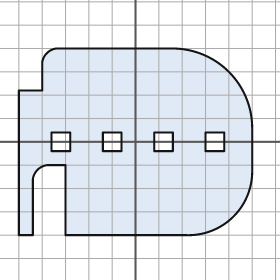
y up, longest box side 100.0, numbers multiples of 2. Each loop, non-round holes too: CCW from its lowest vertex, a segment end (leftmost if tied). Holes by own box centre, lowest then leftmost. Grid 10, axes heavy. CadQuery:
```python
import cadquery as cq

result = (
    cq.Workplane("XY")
    .moveTo(-50.0, -40.0)
    .lineTo(-44.0, -40.0)
    .lineTo(-44.0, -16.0)
    .threePointArc((-42.0, -12.0), (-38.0, -10.0))
    .lineTo(-30.0, -10.0)
    .lineTo(-30.0, -40.0)
    .lineTo(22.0, -40.0)
    .threePointArc((42.0, -32.0), (50.0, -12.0))
    .lineTo(50.0, 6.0)
    .threePointArc((40.0, 30.0), (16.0, 40.0))
    .lineTo(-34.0, 40.0)
    .threePointArc((-38.0, 38.0), (-40.0, 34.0))
    .lineTo(-40.0, 22.0)
    .lineTo(-50.0, 22.0)
    .close()
    .moveTo(-36.0, -4.0)
    .lineTo(-28.0, -4.0)
    .lineTo(-28.0, 4.0)
    .lineTo(-36.0, 4.0)
    .close()
    .moveTo(-14.0, -4.0)
    .lineTo(-6.0, -4.0)
    .lineTo(-6.0, 4.0)
    .lineTo(-14.0, 4.0)
    .close()
    .moveTo(8.0, -4.0)
    .lineTo(16.0, -4.0)
    .lineTo(16.0, 4.0)
    .lineTo(8.0, 4.0)
    .close()
    .moveTo(30.0, -4.0)
    .lineTo(38.0, -4.0)
    .lineTo(38.0, 4.0)
    .lineTo(30.0, 4.0)
    .close()
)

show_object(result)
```